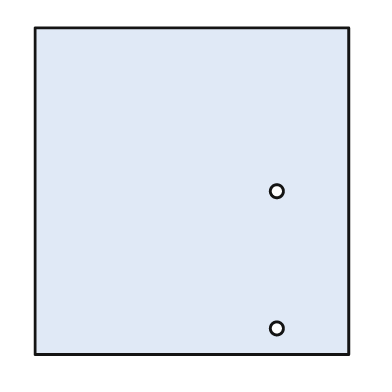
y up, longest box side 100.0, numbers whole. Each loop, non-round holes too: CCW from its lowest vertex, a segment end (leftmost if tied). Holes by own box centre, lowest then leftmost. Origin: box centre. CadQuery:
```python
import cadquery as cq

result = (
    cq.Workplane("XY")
    .moveTo(-48.0, -50.0)
    .lineTo(48.0, -50.0)
    .lineTo(48.0, 50.0)
    .lineTo(-48.0, 50.0)
    .close()
    .moveTo(26.0, -42.0)
    .circle(2.0)
    .moveTo(26.0, 0.0)
    .circle(2.0)
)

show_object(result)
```